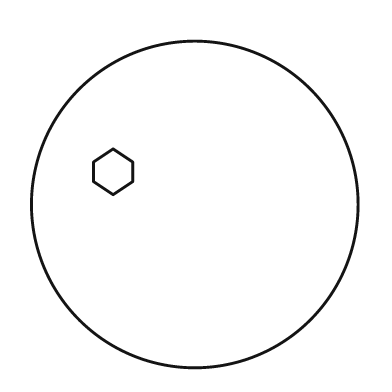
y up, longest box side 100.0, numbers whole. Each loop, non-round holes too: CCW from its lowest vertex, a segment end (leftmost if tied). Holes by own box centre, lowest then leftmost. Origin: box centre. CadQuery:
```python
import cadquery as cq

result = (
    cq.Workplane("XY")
    .moveTo(0.0, 0.0)
    .circle(50.0)
    .moveTo(-25.0, 3.0)
    .lineTo(-19.0, 7.0)
    .lineTo(-19.0, 13.0)
    .lineTo(-25.0, 17.0)
    .lineTo(-31.0, 13.0)
    .lineTo(-31.0, 7.0)
    .close()
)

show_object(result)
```